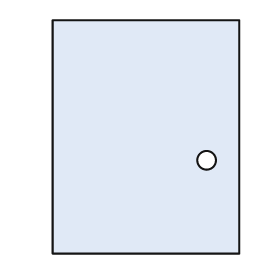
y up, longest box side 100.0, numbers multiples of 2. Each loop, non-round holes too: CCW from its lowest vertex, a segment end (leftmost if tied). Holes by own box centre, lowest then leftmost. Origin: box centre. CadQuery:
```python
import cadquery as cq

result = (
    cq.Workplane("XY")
    .moveTo(-40.0, -50.0)
    .lineTo(40.0, -50.0)
    .lineTo(40.0, 50.0)
    .lineTo(-40.0, 50.0)
    .close()
    .moveTo(26.0, -10.0)
    .circle(4.0)
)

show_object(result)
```